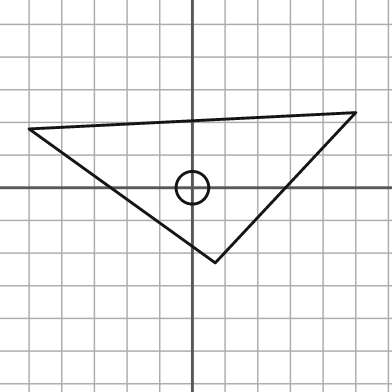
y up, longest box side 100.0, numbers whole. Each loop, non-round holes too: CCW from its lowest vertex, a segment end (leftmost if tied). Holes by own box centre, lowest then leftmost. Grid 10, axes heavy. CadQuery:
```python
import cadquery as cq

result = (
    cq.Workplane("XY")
    .moveTo(7.0, -23.0)
    .lineTo(50.0, 23.0)
    .lineTo(-50.0, 18.0)
    .close()
    .moveTo(0.0, 0.0)
    .circle(5.0)
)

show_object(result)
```